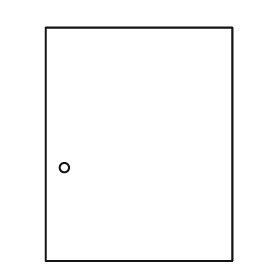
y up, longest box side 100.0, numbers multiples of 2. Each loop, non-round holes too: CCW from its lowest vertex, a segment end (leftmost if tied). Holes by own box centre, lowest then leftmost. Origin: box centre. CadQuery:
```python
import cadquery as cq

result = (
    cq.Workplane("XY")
    .moveTo(-40.0, -50.0)
    .lineTo(40.0, -50.0)
    .lineTo(40.0, 50.0)
    .lineTo(-40.0, 50.0)
    .close()
    .moveTo(-32.0, -10.0)
    .circle(2.0)
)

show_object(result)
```